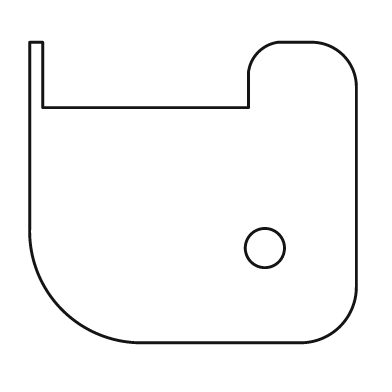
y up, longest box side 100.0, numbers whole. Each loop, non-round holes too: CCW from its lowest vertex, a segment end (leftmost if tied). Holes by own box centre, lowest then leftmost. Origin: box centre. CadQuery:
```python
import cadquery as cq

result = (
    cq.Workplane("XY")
    .moveTo(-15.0, -46.0)
    .lineTo(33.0, -46.0)
    .threePointArc((45.0, -41.0), (50.0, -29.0))
    .lineTo(50.0, 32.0)
    .threePointArc((46.0, 42.0), (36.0, 46.0))
    .lineTo(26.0, 46.0)
    .threePointArc((20.0, 43.0), (17.0, 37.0))
    .lineTo(17.0, 26.0)
    .lineTo(-46.0, 26.0)
    .lineTo(-46.0, 46.0)
    .lineTo(-50.0, 46.0)
    .lineTo(-50.0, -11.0)
    .threePointArc((-40.0, -36.0), (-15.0, -46.0))
    .close()
    .moveTo(22.0, -17.0)
    .circle(6.0)
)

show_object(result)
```